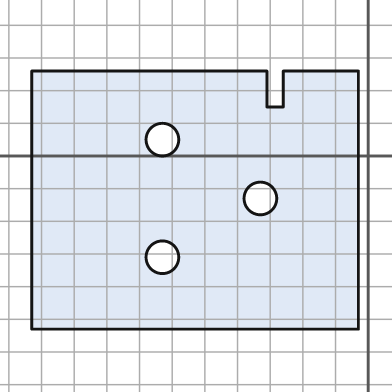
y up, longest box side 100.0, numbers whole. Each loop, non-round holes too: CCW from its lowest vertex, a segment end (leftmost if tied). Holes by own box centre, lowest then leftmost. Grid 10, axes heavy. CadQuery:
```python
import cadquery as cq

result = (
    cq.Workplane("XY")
    .moveTo(-103.0, -53.0)
    .lineTo(-3.0, -53.0)
    .lineTo(-3.0, 26.0)
    .lineTo(-26.0, 26.0)
    .lineTo(-26.0, 15.0)
    .lineTo(-31.0, 15.0)
    .lineTo(-31.0, 26.0)
    .lineTo(-103.0, 26.0)
    .close()
    .moveTo(-63.0, -31.0)
    .circle(5.0)
    .moveTo(-33.0, -13.0)
    .circle(5.0)
    .moveTo(-63.0, 5.0)
    .circle(5.0)
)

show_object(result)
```